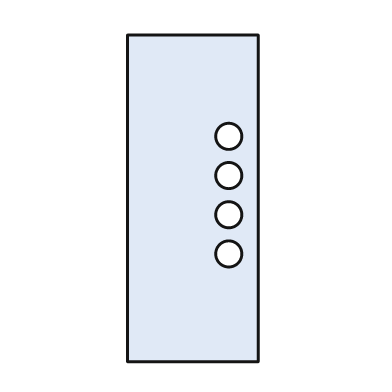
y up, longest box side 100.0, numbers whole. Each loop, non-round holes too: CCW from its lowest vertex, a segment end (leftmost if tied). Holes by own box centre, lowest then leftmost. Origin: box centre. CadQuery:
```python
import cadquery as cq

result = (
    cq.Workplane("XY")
    .moveTo(-20.0, -50.0)
    .lineTo(20.0, -50.0)
    .lineTo(20.0, 50.0)
    .lineTo(-20.0, 50.0)
    .close()
    .moveTo(11.0, -17.0)
    .circle(4.0)
    .moveTo(11.0, -5.0)
    .circle(4.0)
    .moveTo(11.0, 7.0)
    .circle(4.0)
    .moveTo(11.0, 19.0)
    .circle(4.0)
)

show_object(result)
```